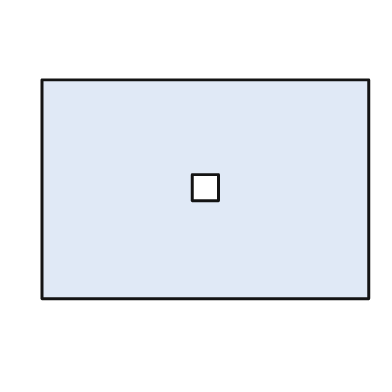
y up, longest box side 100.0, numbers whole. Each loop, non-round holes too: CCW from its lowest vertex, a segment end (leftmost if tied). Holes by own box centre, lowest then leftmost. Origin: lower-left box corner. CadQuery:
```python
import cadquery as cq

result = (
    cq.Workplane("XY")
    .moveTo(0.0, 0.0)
    .lineTo(100.0, 0.0)
    .lineTo(100.0, 67.0)
    .lineTo(0.0, 67.0)
    .close()
    .moveTo(46.0, 30.0)
    .lineTo(54.0, 30.0)
    .lineTo(54.0, 38.0)
    .lineTo(46.0, 38.0)
    .close()
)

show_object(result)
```